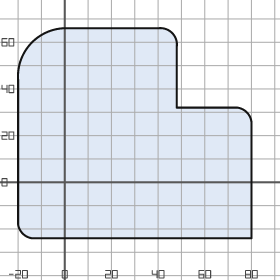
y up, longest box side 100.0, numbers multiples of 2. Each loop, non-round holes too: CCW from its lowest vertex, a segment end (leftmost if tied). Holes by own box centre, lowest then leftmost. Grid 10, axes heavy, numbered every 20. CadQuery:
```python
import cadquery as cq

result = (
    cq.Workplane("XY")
    .moveTo(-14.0, -24.0)
    .lineTo(80.0, -24.0)
    .lineTo(80.0, 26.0)
    .threePointArc((78.0, 30.0), (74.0, 32.0))
    .lineTo(48.0, 32.0)
    .lineTo(48.0, 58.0)
    .threePointArc((46.0, 64.0), (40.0, 66.0))
    .lineTo(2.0, 66.0)
    .threePointArc((-14.0, 60.0), (-20.0, 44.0))
    .lineTo(-20.0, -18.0)
    .threePointArc((-18.0, -22.0), (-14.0, -24.0))
    .close()
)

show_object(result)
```